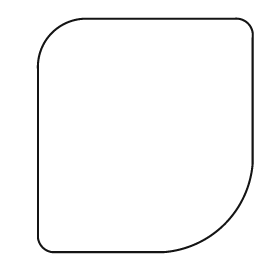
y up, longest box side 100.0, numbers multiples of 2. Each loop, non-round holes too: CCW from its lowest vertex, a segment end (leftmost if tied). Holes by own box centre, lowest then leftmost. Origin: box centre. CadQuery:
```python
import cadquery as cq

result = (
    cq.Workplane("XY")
    .moveTo(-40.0, -50.0)
    .lineTo(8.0, -50.0)
    .threePointArc((34.0, -38.0), (46.0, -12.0))
    .lineTo(46.0, 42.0)
    .threePointArc((44.0, 48.0), (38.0, 50.0))
    .lineTo(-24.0, 50.0)
    .threePointArc((-40.0, 44.0), (-46.0, 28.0))
    .lineTo(-46.0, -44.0)
    .threePointArc((-44.0, -48.0), (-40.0, -50.0))
    .close()
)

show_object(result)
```